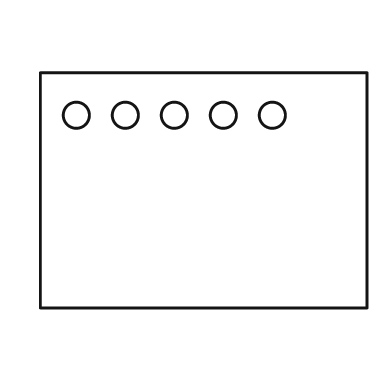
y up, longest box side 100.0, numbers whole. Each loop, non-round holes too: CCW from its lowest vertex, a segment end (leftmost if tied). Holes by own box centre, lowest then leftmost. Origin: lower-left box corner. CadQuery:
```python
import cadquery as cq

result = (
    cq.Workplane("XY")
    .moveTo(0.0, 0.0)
    .lineTo(100.0, 0.0)
    .lineTo(100.0, 72.0)
    .lineTo(0.0, 72.0)
    .close()
    .moveTo(11.0, 59.0)
    .circle(4.0)
    .moveTo(26.0, 59.0)
    .circle(4.0)
    .moveTo(41.0, 59.0)
    .circle(4.0)
    .moveTo(56.0, 59.0)
    .circle(4.0)
    .moveTo(71.0, 59.0)
    .circle(4.0)
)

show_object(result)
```